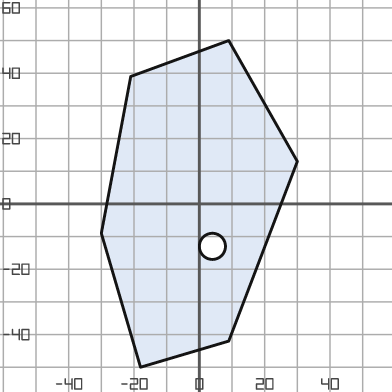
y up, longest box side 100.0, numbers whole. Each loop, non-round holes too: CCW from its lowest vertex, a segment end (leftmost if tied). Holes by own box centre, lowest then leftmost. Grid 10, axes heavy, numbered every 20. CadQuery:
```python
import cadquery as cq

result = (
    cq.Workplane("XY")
    .moveTo(-18.0, -50.0)
    .lineTo(9.0, -42.0)
    .lineTo(30.0, 13.0)
    .lineTo(9.0, 50.0)
    .lineTo(-21.0, 39.0)
    .lineTo(-30.0, -9.0)
    .close()
    .moveTo(4.0, -13.0)
    .circle(4.0)
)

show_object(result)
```